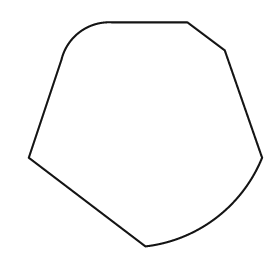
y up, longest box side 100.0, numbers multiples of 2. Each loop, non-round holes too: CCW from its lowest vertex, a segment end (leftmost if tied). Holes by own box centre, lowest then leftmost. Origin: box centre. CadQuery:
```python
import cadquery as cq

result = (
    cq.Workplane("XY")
    .moveTo(0.0, -48.0)
    .threePointArc((30.0, -36.0), (50.0, -10.0))
    .lineTo(34.0, 36.0)
    .lineTo(18.0, 48.0)
    .lineTo(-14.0, 48.0)
    .threePointArc((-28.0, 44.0), (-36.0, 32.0))
    .lineTo(-50.0, -10.0)
    .close()
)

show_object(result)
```